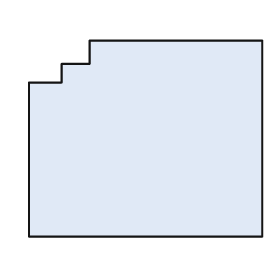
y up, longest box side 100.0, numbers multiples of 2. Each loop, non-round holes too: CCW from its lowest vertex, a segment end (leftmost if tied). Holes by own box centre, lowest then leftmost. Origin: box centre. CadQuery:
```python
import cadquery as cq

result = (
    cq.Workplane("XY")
    .moveTo(-50.0, -42.0)
    .lineTo(50.0, -42.0)
    .lineTo(50.0, 42.0)
    .lineTo(-24.0, 42.0)
    .lineTo(-24.0, 32.0)
    .lineTo(-36.0, 32.0)
    .lineTo(-36.0, 24.0)
    .lineTo(-50.0, 24.0)
    .close()
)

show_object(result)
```